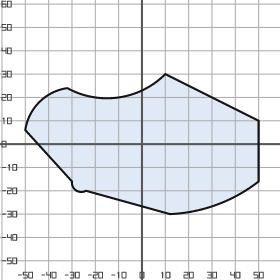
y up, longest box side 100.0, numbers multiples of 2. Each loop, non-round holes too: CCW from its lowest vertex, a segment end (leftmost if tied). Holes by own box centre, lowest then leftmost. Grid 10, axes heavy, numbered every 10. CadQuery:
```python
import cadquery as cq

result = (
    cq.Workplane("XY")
    .moveTo(12.0, -30.0)
    .threePointArc((32.0, -26.0), (50.0, -16.0))
    .lineTo(50.0, 10.0)
    .lineTo(10.0, 30.0)
    .threePointArc((-10.0, 20.0), (-32.0, 24.0))
    .threePointArc((-44.0, 18.0), (-50.0, 6.0))
    .lineTo(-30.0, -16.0)
    .threePointArc((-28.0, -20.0), (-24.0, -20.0))
    .close()
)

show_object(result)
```